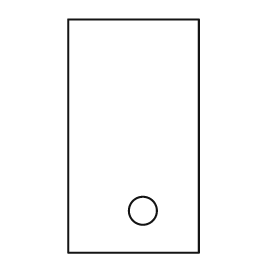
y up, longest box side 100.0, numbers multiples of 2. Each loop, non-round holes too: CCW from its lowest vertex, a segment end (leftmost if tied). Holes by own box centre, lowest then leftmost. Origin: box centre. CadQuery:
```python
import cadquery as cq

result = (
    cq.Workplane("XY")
    .moveTo(-28.0, -50.0)
    .lineTo(28.0, -50.0)
    .lineTo(28.0, 50.0)
    .lineTo(-28.0, 50.0)
    .close()
    .moveTo(4.0, -32.0)
    .circle(6.0)
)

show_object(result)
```